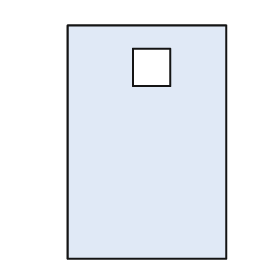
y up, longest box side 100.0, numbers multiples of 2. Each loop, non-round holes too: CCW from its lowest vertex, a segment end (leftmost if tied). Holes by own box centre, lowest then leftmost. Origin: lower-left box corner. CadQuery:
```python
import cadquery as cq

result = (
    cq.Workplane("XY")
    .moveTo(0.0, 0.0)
    .lineTo(68.0, 0.0)
    .lineTo(68.0, 100.0)
    .lineTo(0.0, 100.0)
    .close()
    .moveTo(28.0, 74.0)
    .lineTo(44.0, 74.0)
    .lineTo(44.0, 90.0)
    .lineTo(28.0, 90.0)
    .close()
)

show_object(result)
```